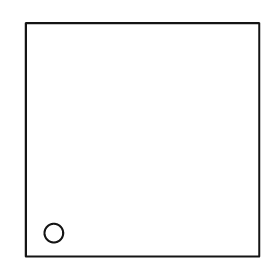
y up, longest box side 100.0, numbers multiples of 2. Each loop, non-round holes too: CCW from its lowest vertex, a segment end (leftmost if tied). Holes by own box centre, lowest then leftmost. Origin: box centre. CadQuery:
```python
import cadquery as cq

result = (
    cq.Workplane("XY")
    .moveTo(-50.0, -50.0)
    .lineTo(50.0, -50.0)
    .lineTo(50.0, 50.0)
    .lineTo(-50.0, 50.0)
    .close()
    .moveTo(-38.0, -40.0)
    .circle(4.0)
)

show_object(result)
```